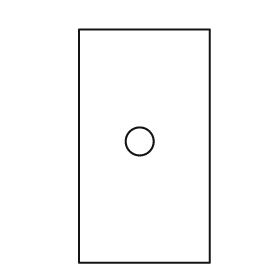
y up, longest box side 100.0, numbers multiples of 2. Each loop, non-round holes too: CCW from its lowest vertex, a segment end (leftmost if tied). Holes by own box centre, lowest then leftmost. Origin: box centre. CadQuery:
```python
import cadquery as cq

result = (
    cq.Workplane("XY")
    .moveTo(-28.0, -50.0)
    .lineTo(28.0, -50.0)
    .lineTo(28.0, 50.0)
    .lineTo(-28.0, 50.0)
    .close()
    .moveTo(-2.0, 2.0)
    .circle(6.0)
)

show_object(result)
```